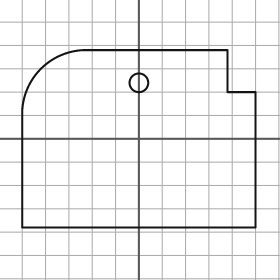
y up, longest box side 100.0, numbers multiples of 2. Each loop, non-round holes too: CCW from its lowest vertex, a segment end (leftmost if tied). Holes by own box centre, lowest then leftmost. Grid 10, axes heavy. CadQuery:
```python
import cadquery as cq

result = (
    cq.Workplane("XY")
    .moveTo(-50.0, -38.0)
    .lineTo(50.0, -38.0)
    .lineTo(50.0, 20.0)
    .lineTo(38.0, 20.0)
    .lineTo(38.0, 38.0)
    .lineTo(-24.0, 38.0)
    .threePointArc((-42.0, 30.0), (-50.0, 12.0))
    .close()
    .moveTo(0.0, 24.0)
    .circle(4.0)
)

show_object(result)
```